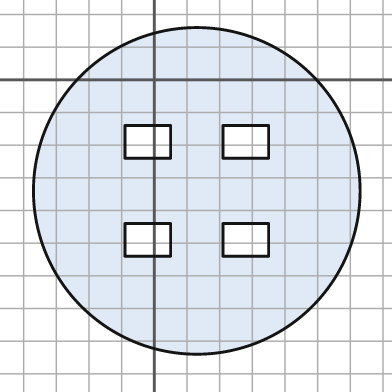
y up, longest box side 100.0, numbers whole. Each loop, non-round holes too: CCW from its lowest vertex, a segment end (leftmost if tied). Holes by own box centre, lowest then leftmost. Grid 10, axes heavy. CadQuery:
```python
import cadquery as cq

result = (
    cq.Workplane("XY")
    .moveTo(13.0, -34.0)
    .circle(50.0)
    .moveTo(-9.0, -54.0)
    .lineTo(5.0, -54.0)
    .lineTo(5.0, -44.0)
    .lineTo(-9.0, -44.0)
    .close()
    .moveTo(21.0, -54.0)
    .lineTo(35.0, -54.0)
    .lineTo(35.0, -44.0)
    .lineTo(21.0, -44.0)
    .close()
    .moveTo(-9.0, -24.0)
    .lineTo(5.0, -24.0)
    .lineTo(5.0, -14.0)
    .lineTo(-9.0, -14.0)
    .close()
    .moveTo(21.0, -24.0)
    .lineTo(35.0, -24.0)
    .lineTo(35.0, -14.0)
    .lineTo(21.0, -14.0)
    .close()
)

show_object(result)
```